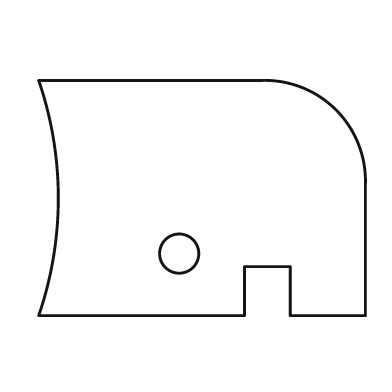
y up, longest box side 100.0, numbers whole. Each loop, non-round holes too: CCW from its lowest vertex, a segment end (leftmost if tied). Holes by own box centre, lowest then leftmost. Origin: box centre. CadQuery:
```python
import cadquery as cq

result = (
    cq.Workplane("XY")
    .moveTo(-50.0, -36.0)
    .lineTo(13.0, -36.0)
    .lineTo(13.0, -21.0)
    .lineTo(27.0, -21.0)
    .lineTo(27.0, -36.0)
    .lineTo(50.0, -36.0)
    .lineTo(50.0, 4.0)
    .threePointArc((41.0, 27.0), (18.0, 36.0))
    .lineTo(-50.0, 36.0)
    .threePointArc((-44.0, 0.0), (-50.0, -36.0))
    .close()
    .moveTo(-7.0, -17.0)
    .circle(6.0)
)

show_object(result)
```